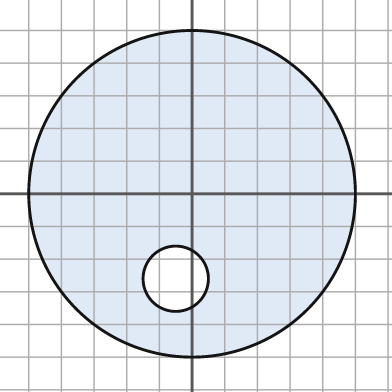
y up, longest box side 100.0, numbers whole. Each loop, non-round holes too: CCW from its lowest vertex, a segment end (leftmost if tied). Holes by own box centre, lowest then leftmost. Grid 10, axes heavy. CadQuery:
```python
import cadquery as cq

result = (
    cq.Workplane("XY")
    .moveTo(0.0, 0.0)
    .circle(50.0)
    .moveTo(-5.0, -26.0)
    .circle(10.0)
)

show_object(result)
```